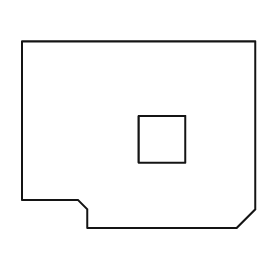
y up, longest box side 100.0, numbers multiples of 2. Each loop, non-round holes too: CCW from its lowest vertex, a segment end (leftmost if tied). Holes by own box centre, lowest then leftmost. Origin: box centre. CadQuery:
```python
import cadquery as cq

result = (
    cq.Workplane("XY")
    .moveTo(-22.0, -40.0)
    .lineTo(42.0, -40.0)
    .lineTo(50.0, -32.0)
    .lineTo(50.0, 40.0)
    .lineTo(-50.0, 40.0)
    .lineTo(-50.0, -28.0)
    .lineTo(-26.0, -28.0)
    .lineTo(-22.0, -32.0)
    .close()
    .moveTo(0.0, -12.0)
    .lineTo(20.0, -12.0)
    .lineTo(20.0, 8.0)
    .lineTo(0.0, 8.0)
    .close()
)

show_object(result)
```